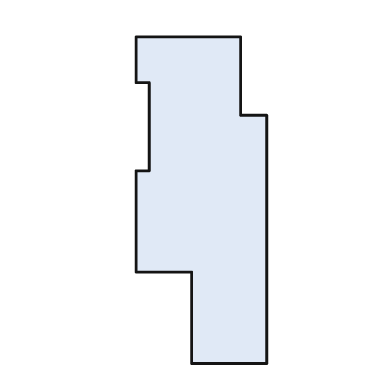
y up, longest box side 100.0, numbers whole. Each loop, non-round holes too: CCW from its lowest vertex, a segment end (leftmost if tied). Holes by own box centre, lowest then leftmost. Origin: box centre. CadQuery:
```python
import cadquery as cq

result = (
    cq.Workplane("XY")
    .moveTo(-3.0, -50.0)
    .lineTo(20.0, -50.0)
    .lineTo(20.0, 26.0)
    .lineTo(12.0, 26.0)
    .lineTo(12.0, 50.0)
    .lineTo(-20.0, 50.0)
    .lineTo(-20.0, 36.0)
    .lineTo(-16.0, 36.0)
    .lineTo(-16.0, 9.0)
    .lineTo(-20.0, 9.0)
    .lineTo(-20.0, -22.0)
    .lineTo(-3.0, -22.0)
    .close()
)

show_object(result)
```